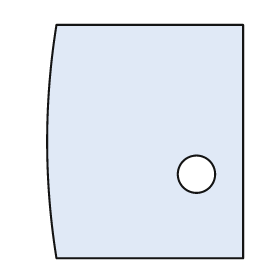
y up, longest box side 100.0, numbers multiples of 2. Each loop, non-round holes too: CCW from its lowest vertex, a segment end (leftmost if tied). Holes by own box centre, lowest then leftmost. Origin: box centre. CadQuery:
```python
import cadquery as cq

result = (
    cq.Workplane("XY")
    .moveTo(-38.0, -50.0)
    .lineTo(42.0, -50.0)
    .lineTo(42.0, 50.0)
    .lineTo(-38.0, 50.0)
    .threePointArc((-42.0, 0.0), (-38.0, -50.0))
    .close()
    .moveTo(22.0, -14.0)
    .circle(8.0)
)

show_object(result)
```